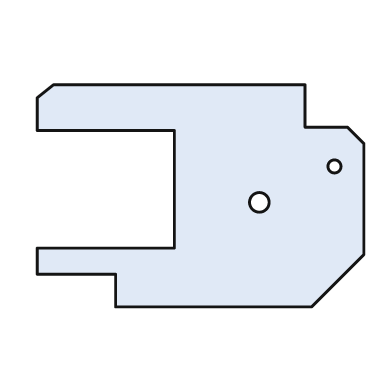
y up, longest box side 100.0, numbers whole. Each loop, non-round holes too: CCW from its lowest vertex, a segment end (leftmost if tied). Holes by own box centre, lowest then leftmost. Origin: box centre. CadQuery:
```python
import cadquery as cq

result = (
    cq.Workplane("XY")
    .moveTo(-26.0, -34.0)
    .lineTo(34.0, -34.0)
    .lineTo(50.0, -18.0)
    .lineTo(50.0, 16.0)
    .lineTo(45.0, 21.0)
    .lineTo(32.0, 21.0)
    .lineTo(32.0, 34.0)
    .lineTo(-45.0, 34.0)
    .lineTo(-50.0, 30.0)
    .lineTo(-50.0, 20.0)
    .lineTo(-8.0, 20.0)
    .lineTo(-8.0, -16.0)
    .lineTo(-50.0, -16.0)
    .lineTo(-50.0, -24.0)
    .lineTo(-26.0, -24.0)
    .close()
    .moveTo(18.0, -2.0)
    .circle(3.0)
    .moveTo(41.0, 9.0)
    .circle(2.0)
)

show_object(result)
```